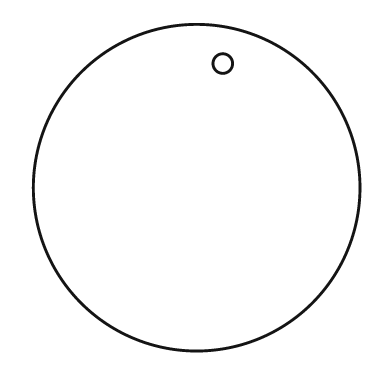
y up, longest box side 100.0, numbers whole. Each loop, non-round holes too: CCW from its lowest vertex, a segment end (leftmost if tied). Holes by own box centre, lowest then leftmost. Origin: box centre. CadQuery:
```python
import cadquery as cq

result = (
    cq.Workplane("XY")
    .moveTo(0.0, 0.0)
    .circle(50.0)
    .moveTo(8.0, 38.0)
    .circle(3.0)
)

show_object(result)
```